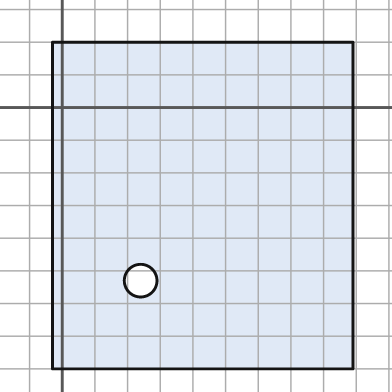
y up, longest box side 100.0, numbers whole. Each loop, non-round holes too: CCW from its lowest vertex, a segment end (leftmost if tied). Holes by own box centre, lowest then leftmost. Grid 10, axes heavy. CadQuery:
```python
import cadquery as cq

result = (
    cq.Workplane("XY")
    .moveTo(-3.0, -80.0)
    .lineTo(89.0, -80.0)
    .lineTo(89.0, 20.0)
    .lineTo(-3.0, 20.0)
    .close()
    .moveTo(24.0, -53.0)
    .circle(5.0)
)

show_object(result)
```